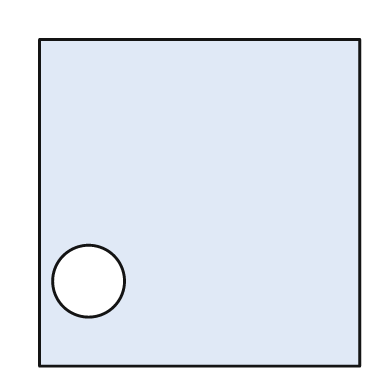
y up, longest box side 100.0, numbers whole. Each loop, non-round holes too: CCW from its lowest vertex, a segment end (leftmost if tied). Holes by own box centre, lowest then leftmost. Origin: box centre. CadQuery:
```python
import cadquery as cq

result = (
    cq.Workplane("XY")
    .moveTo(-49.0, -50.0)
    .lineTo(49.0, -50.0)
    .lineTo(49.0, 50.0)
    .lineTo(-49.0, 50.0)
    .close()
    .moveTo(-34.0, -24.0)
    .circle(11.0)
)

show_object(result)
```